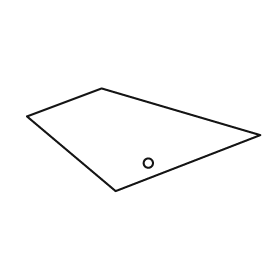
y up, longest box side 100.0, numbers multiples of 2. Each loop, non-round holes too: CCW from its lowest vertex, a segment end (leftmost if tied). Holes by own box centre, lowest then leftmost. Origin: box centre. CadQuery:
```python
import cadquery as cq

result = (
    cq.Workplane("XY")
    .moveTo(-12.0, -22.0)
    .lineTo(50.0, 2.0)
    .lineTo(-18.0, 22.0)
    .lineTo(-50.0, 10.0)
    .close()
    .moveTo(2.0, -10.0)
    .circle(2.0)
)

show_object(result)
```